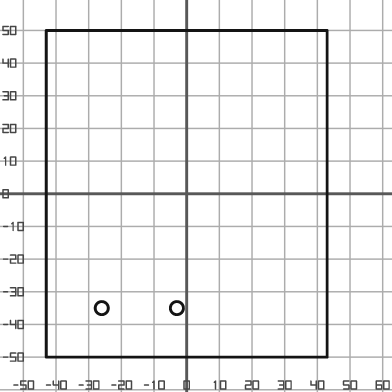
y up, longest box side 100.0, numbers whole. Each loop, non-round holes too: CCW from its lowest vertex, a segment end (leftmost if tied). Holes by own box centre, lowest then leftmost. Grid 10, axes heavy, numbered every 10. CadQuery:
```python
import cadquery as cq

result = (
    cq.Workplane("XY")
    .moveTo(-43.0, -50.0)
    .lineTo(43.0, -50.0)
    .lineTo(43.0, 50.0)
    .lineTo(-43.0, 50.0)
    .close()
    .moveTo(-26.0, -35.0)
    .circle(2.0)
    .moveTo(-3.0, -35.0)
    .circle(2.0)
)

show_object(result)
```